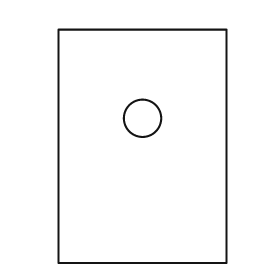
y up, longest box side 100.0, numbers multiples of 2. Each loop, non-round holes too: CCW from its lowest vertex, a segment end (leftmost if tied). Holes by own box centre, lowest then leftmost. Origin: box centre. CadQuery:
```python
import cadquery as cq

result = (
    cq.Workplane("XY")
    .moveTo(-36.0, -50.0)
    .lineTo(36.0, -50.0)
    .lineTo(36.0, 50.0)
    .lineTo(-36.0, 50.0)
    .close()
    .moveTo(0.0, 12.0)
    .circle(8.0)
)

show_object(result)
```